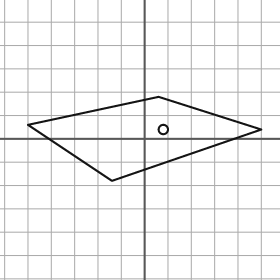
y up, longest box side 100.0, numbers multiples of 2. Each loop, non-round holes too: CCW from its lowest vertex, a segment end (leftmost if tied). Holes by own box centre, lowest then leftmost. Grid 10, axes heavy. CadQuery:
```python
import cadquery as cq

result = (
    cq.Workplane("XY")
    .moveTo(-14.0, -18.0)
    .lineTo(50.0, 4.0)
    .lineTo(6.0, 18.0)
    .lineTo(-50.0, 6.0)
    .close()
    .moveTo(8.0, 4.0)
    .circle(2.0)
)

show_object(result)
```